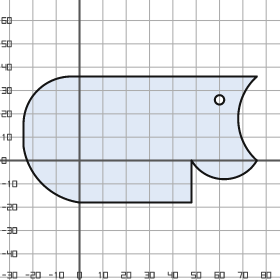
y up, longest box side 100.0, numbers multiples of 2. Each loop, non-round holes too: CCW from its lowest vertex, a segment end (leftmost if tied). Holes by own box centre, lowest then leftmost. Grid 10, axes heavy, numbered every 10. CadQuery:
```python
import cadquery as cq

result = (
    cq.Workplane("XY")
    .moveTo(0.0, -18.0)
    .lineTo(48.0, -18.0)
    .lineTo(48.0, 0.0)
    .threePointArc((62.0, -8.0), (76.0, 0.0))
    .threePointArc((68.0, 18.0), (76.0, 36.0))
    .lineTo(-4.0, 36.0)
    .threePointArc((-18.0, 30.0), (-24.0, 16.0))
    .lineTo(-24.0, 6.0)
    .threePointArc((-16.0, -10.0), (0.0, -18.0))
    .close()
    .moveTo(60.0, 26.0)
    .circle(2.0)
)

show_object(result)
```